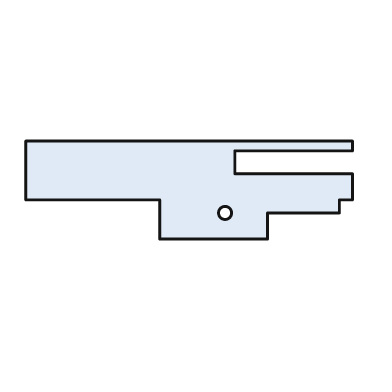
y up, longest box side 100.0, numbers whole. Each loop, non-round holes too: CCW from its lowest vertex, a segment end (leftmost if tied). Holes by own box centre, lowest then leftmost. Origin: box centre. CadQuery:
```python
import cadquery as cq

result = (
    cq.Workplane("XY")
    .moveTo(-9.0, -15.0)
    .lineTo(24.0, -15.0)
    .lineTo(24.0, -7.0)
    .lineTo(46.0, -7.0)
    .lineTo(46.0, -3.0)
    .lineTo(50.0, -3.0)
    .lineTo(50.0, 5.0)
    .lineTo(14.0, 5.0)
    .lineTo(14.0, 12.0)
    .lineTo(50.0, 12.0)
    .lineTo(50.0, 15.0)
    .lineTo(-50.0, 15.0)
    .lineTo(-50.0, -3.0)
    .lineTo(-9.0, -3.0)
    .close()
    .moveTo(11.0, -7.0)
    .circle(2.0)
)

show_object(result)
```